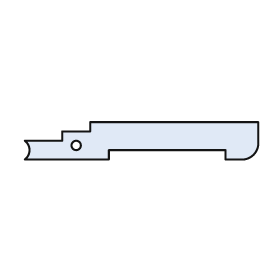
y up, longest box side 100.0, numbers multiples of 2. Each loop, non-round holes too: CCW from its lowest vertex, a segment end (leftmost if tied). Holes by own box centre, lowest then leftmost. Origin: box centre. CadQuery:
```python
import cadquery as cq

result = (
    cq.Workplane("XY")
    .moveTo(-50.0, -8.0)
    .lineTo(-14.0, -8.0)
    .lineTo(-14.0, -4.0)
    .lineTo(36.0, -4.0)
    .lineTo(36.0, -8.0)
    .lineTo(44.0, -8.0)
    .threePointArc((48.0, -6.0), (50.0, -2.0))
    .lineTo(50.0, 8.0)
    .lineTo(-22.0, 8.0)
    .lineTo(-22.0, 4.0)
    .lineTo(-34.0, 4.0)
    .lineTo(-34.0, 0.0)
    .lineTo(-50.0, 0.0)
    .threePointArc((-48.0, -4.0), (-50.0, -8.0))
    .close()
    .moveTo(-28.0, -2.0)
    .circle(2.0)
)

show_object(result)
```